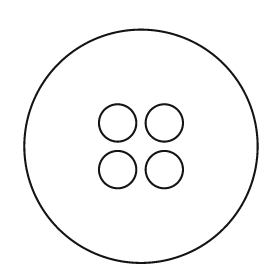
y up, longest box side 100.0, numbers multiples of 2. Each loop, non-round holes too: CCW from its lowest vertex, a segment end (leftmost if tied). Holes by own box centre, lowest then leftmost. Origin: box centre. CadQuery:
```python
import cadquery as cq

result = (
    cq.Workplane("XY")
    .moveTo(0.0, 0.0)
    .circle(50.0)
    .moveTo(-10.0, -10.0)
    .circle(8.0)
    .moveTo(10.0, -10.0)
    .circle(8.0)
    .moveTo(-10.0, 10.0)
    .circle(8.0)
    .moveTo(10.0, 10.0)
    .circle(8.0)
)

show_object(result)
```